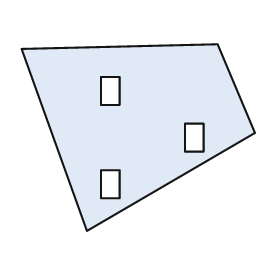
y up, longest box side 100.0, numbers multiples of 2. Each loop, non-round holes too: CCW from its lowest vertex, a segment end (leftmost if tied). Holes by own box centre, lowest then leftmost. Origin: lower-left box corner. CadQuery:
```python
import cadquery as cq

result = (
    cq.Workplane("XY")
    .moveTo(28.0, 0.0)
    .lineTo(100.0, 42.0)
    .lineTo(84.0, 80.0)
    .lineTo(0.0, 78.0)
    .close()
    .moveTo(34.0, 14.0)
    .lineTo(42.0, 14.0)
    .lineTo(42.0, 26.0)
    .lineTo(34.0, 26.0)
    .close()
    .moveTo(70.0, 34.0)
    .lineTo(78.0, 34.0)
    .lineTo(78.0, 46.0)
    .lineTo(70.0, 46.0)
    .close()
    .moveTo(34.0, 54.0)
    .lineTo(42.0, 54.0)
    .lineTo(42.0, 66.0)
    .lineTo(34.0, 66.0)
    .close()
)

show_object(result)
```